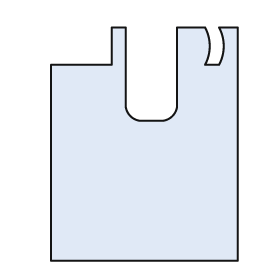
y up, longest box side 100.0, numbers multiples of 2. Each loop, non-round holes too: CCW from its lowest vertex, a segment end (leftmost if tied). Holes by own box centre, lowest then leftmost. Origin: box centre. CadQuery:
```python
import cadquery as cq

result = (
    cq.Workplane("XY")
    .moveTo(-40.0, -50.0)
    .lineTo(40.0, -50.0)
    .lineTo(40.0, 50.0)
    .lineTo(32.0, 50.0)
    .threePointArc((34.0, 42.0), (32.0, 34.0))
    .lineTo(26.0, 34.0)
    .threePointArc((28.0, 42.0), (26.0, 50.0))
    .lineTo(14.0, 50.0)
    .lineTo(14.0, 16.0)
    .threePointArc((12.0, 12.0), (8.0, 10.0))
    .lineTo(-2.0, 10.0)
    .threePointArc((-6.0, 12.0), (-8.0, 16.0))
    .lineTo(-8.0, 50.0)
    .lineTo(-14.0, 50.0)
    .lineTo(-14.0, 34.0)
    .lineTo(-40.0, 34.0)
    .close()
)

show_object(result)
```